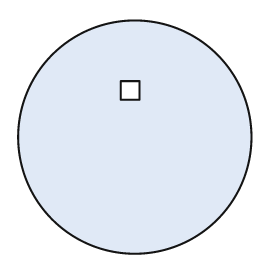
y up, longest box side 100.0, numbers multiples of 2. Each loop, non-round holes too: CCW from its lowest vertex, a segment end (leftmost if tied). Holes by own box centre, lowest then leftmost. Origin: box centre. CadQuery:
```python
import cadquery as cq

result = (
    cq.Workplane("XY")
    .moveTo(0.0, 0.0)
    .circle(50.0)
    .moveTo(-6.0, 16.0)
    .lineTo(2.0, 16.0)
    .lineTo(2.0, 24.0)
    .lineTo(-6.0, 24.0)
    .close()
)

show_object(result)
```